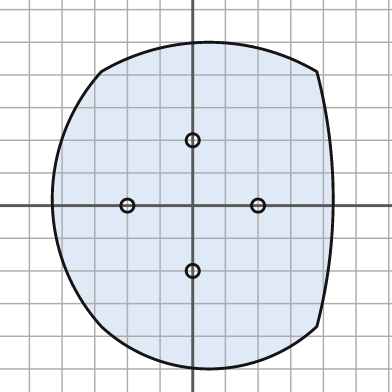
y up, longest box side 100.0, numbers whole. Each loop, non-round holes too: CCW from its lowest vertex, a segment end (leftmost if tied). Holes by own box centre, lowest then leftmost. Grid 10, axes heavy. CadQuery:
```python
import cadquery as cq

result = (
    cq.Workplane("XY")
    .moveTo(-28.0, -37.0)
    .threePointArc((5.0, -50.0), (38.0, -37.0))
    .threePointArc((43.0, 2.0), (38.0, 41.0))
    .threePointArc((5.0, 50.0), (-28.0, 41.0))
    .threePointArc((-43.0, 2.0), (-28.0, -37.0))
    .close()
    .moveTo(0.0, -20.0)
    .circle(2.0)
    .moveTo(-20.0, 0.0)
    .circle(2.0)
    .moveTo(20.0, 0.0)
    .circle(2.0)
    .moveTo(0.0, 20.0)
    .circle(2.0)
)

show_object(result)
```